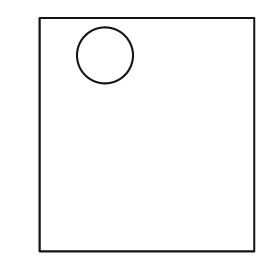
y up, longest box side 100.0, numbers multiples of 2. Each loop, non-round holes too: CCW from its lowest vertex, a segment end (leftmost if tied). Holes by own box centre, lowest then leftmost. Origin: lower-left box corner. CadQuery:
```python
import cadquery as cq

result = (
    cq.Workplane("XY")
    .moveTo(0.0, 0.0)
    .lineTo(92.0, 0.0)
    .lineTo(92.0, 100.0)
    .lineTo(0.0, 100.0)
    .close()
    .moveTo(28.0, 84.0)
    .circle(12.0)
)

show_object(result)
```